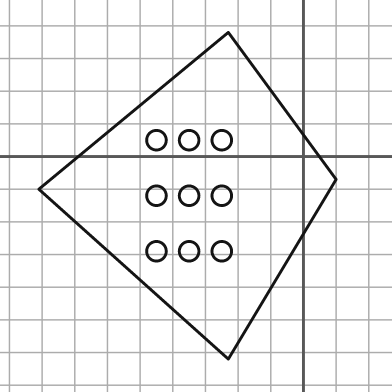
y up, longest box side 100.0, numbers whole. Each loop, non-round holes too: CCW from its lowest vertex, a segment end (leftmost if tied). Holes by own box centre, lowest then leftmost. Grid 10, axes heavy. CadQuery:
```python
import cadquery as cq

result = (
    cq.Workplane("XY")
    .moveTo(-23.0, -62.0)
    .lineTo(10.0, -7.0)
    .lineTo(-23.0, 38.0)
    .lineTo(-81.0, -10.0)
    .close()
    .moveTo(-45.0, -29.0)
    .circle(3.0)
    .moveTo(-35.0, -29.0)
    .circle(3.0)
    .moveTo(-25.0, -29.0)
    .circle(3.0)
    .moveTo(-45.0, -12.0)
    .circle(3.0)
    .moveTo(-35.0, -12.0)
    .circle(3.0)
    .moveTo(-25.0, -12.0)
    .circle(3.0)
    .moveTo(-45.0, 5.0)
    .circle(3.0)
    .moveTo(-35.0, 5.0)
    .circle(3.0)
    .moveTo(-25.0, 5.0)
    .circle(3.0)
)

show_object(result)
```